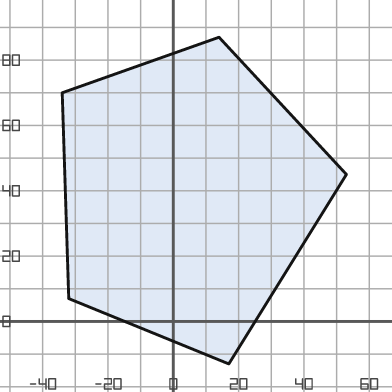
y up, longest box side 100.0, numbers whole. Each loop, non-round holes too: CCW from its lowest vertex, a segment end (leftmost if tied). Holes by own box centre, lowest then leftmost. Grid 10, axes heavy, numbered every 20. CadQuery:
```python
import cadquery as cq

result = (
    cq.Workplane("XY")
    .moveTo(17.0, -13.0)
    .lineTo(53.0, 45.0)
    .lineTo(14.0, 87.0)
    .lineTo(-34.0, 70.0)
    .lineTo(-32.0, 7.0)
    .close()
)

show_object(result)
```